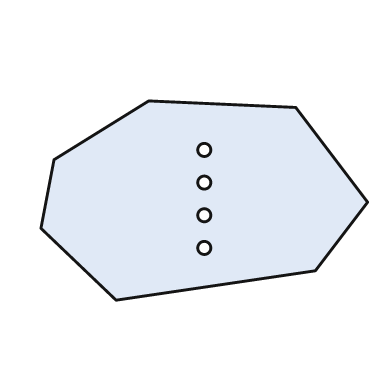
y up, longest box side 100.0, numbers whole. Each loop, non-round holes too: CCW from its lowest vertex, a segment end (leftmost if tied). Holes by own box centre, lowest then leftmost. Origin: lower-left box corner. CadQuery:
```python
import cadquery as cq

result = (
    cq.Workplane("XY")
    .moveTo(23.0, 0.0)
    .lineTo(84.0, 9.0)
    .lineTo(100.0, 30.0)
    .lineTo(78.0, 59.0)
    .lineTo(33.0, 61.0)
    .lineTo(4.0, 43.0)
    .lineTo(0.0, 22.0)
    .close()
    .moveTo(50.0, 16.0)
    .circle(2.0)
    .moveTo(50.0, 26.0)
    .circle(2.0)
    .moveTo(50.0, 36.0)
    .circle(2.0)
    .moveTo(50.0, 46.0)
    .circle(2.0)
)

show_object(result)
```